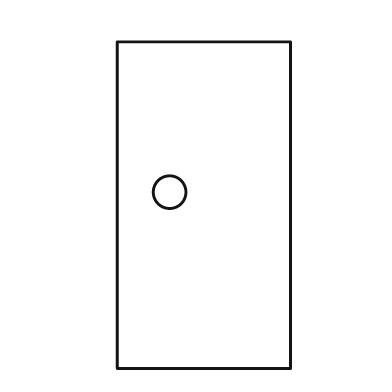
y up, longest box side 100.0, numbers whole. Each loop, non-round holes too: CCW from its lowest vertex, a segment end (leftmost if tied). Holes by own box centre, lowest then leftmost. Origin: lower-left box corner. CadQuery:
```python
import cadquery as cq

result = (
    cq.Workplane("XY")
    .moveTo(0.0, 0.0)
    .lineTo(53.0, 0.0)
    .lineTo(53.0, 100.0)
    .lineTo(0.0, 100.0)
    .close()
    .moveTo(16.0, 54.0)
    .circle(5.0)
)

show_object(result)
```